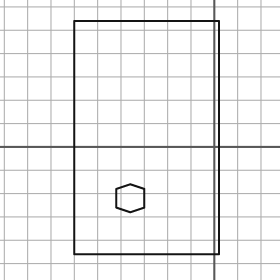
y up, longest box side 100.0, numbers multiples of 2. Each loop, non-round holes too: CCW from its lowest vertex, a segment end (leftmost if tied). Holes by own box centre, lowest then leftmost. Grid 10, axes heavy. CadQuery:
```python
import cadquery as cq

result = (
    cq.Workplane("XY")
    .moveTo(-60.0, -46.0)
    .lineTo(2.0, -46.0)
    .lineTo(2.0, 54.0)
    .lineTo(-60.0, 54.0)
    .close()
    .moveTo(-36.0, -28.0)
    .lineTo(-30.0, -26.0)
    .lineTo(-30.0, -18.0)
    .lineTo(-36.0, -16.0)
    .lineTo(-42.0, -18.0)
    .lineTo(-42.0, -26.0)
    .close()
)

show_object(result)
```